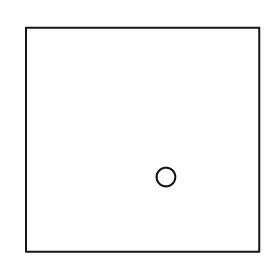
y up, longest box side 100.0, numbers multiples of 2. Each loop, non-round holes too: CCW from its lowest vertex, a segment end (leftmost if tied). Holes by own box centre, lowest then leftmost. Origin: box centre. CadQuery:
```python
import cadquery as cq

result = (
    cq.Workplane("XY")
    .moveTo(-50.0, -48.0)
    .lineTo(50.0, -48.0)
    .lineTo(50.0, 48.0)
    .lineTo(-50.0, 48.0)
    .close()
    .moveTo(10.0, -16.0)
    .circle(4.0)
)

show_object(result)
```